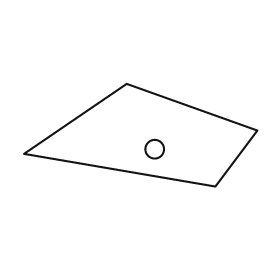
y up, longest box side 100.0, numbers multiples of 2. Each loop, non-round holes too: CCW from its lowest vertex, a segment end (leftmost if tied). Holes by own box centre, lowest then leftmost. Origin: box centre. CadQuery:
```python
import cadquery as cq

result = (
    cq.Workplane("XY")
    .moveTo(32.0, -22.0)
    .lineTo(50.0, 2.0)
    .lineTo(-6.0, 22.0)
    .lineTo(-50.0, -8.0)
    .close()
    .moveTo(6.0, -6.0)
    .circle(4.0)
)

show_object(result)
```